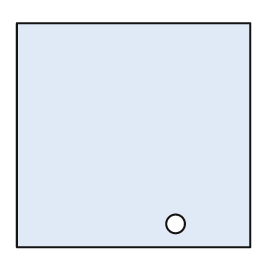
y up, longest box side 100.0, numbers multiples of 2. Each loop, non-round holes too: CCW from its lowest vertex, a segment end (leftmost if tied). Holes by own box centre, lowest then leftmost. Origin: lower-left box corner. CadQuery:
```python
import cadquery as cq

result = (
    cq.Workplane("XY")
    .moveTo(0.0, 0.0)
    .lineTo(100.0, 0.0)
    .lineTo(100.0, 96.0)
    .lineTo(0.0, 96.0)
    .close()
    .moveTo(68.0, 10.0)
    .circle(4.0)
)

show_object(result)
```